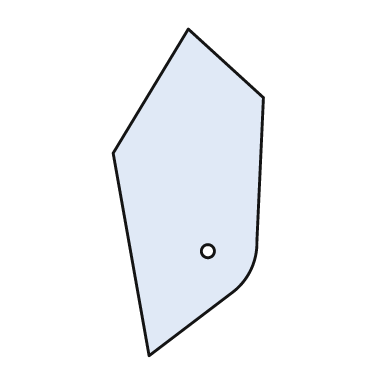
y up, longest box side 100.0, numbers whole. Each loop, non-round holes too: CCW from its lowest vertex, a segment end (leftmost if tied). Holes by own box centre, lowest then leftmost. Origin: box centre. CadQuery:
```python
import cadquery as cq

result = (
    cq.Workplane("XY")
    .moveTo(-12.0, -50.0)
    .lineTo(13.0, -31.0)
    .threePointArc((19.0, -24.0), (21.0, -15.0))
    .lineTo(23.0, 29.0)
    .lineTo(0.0, 50.0)
    .lineTo(-23.0, 12.0)
    .close()
    .moveTo(6.0, -18.0)
    .circle(2.0)
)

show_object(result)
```